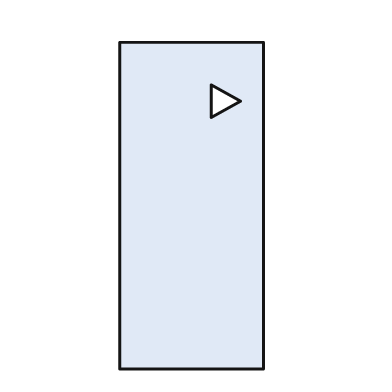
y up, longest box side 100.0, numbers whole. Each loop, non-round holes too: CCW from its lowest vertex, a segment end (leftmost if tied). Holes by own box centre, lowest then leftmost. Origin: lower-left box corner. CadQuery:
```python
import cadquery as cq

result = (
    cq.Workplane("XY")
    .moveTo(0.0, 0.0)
    .lineTo(44.0, 0.0)
    .lineTo(44.0, 100.0)
    .lineTo(0.0, 100.0)
    .close()
    .moveTo(28.0, 77.0)
    .lineTo(37.0, 82.0)
    .lineTo(28.0, 87.0)
    .close()
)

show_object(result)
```